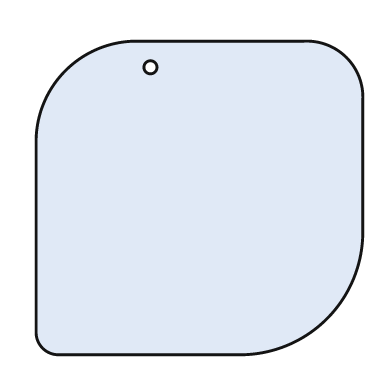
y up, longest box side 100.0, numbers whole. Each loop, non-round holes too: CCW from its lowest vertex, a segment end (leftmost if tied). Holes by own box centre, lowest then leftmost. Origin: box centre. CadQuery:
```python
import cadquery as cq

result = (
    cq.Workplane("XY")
    .moveTo(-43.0, -48.0)
    .lineTo(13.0, -48.0)
    .threePointArc((39.0, -37.0), (50.0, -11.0))
    .lineTo(50.0, 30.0)
    .threePointArc((45.0, 43.0), (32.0, 48.0))
    .lineTo(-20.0, 48.0)
    .threePointArc((-41.0, 39.0), (-50.0, 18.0))
    .lineTo(-50.0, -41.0)
    .threePointArc((-48.0, -46.0), (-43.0, -48.0))
    .close()
    .moveTo(-15.0, 40.0)
    .circle(2.0)
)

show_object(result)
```